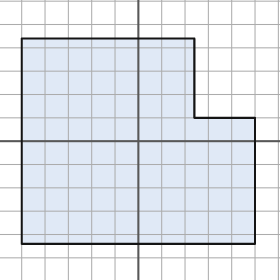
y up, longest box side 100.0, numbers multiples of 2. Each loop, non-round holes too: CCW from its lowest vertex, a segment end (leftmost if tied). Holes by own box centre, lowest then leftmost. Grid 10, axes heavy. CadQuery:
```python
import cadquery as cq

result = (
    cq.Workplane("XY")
    .moveTo(-50.0, -44.0)
    .lineTo(50.0, -44.0)
    .lineTo(50.0, 10.0)
    .lineTo(24.0, 10.0)
    .lineTo(24.0, 44.0)
    .lineTo(-50.0, 44.0)
    .close()
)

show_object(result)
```